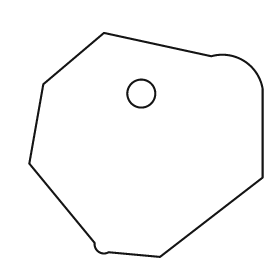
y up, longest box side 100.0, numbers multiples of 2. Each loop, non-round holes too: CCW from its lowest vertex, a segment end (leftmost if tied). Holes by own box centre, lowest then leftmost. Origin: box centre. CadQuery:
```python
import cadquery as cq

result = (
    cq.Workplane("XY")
    .moveTo(6.0, -48.0)
    .lineTo(50.0, -14.0)
    .lineTo(50.0, 24.0)
    .threePointArc((42.0, 36.0), (28.0, 38.0))
    .lineTo(-18.0, 48.0)
    .lineTo(-44.0, 26.0)
    .lineTo(-50.0, -8.0)
    .lineTo(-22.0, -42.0)
    .threePointArc((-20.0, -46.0), (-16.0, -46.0))
    .close()
    .moveTo(-2.0, 22.0)
    .circle(6.0)
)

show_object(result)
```